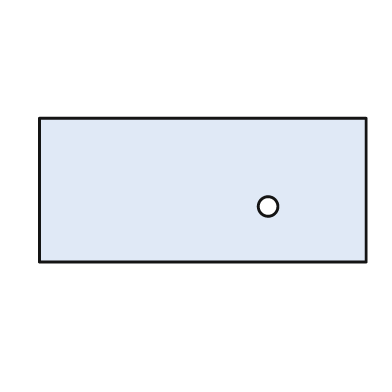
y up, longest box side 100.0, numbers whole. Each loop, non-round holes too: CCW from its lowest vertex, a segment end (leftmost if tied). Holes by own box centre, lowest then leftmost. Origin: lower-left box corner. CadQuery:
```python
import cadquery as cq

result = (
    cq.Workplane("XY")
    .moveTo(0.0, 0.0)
    .lineTo(100.0, 0.0)
    .lineTo(100.0, 44.0)
    .lineTo(0.0, 44.0)
    .close()
    .moveTo(70.0, 17.0)
    .circle(3.0)
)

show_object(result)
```